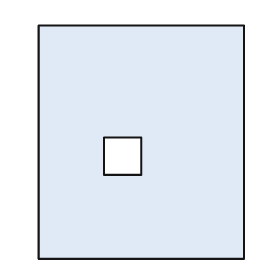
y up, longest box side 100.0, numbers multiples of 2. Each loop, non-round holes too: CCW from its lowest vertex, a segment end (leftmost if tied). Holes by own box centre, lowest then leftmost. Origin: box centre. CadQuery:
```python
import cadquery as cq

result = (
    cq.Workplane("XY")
    .moveTo(-44.0, -50.0)
    .lineTo(44.0, -50.0)
    .lineTo(44.0, 50.0)
    .lineTo(-44.0, 50.0)
    .close()
    .moveTo(-16.0, -14.0)
    .lineTo(0.0, -14.0)
    .lineTo(0.0, 2.0)
    .lineTo(-16.0, 2.0)
    .close()
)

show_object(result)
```